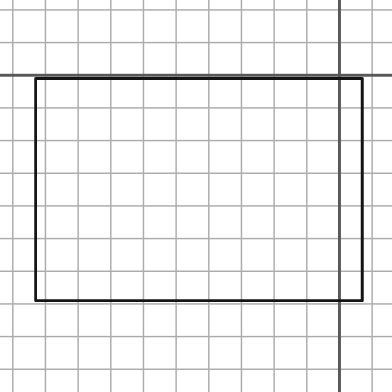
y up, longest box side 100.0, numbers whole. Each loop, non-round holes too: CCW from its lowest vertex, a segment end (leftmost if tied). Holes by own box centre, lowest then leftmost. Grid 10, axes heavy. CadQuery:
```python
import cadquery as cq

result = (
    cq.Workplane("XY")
    .moveTo(-93.0, -69.0)
    .lineTo(7.0, -69.0)
    .lineTo(7.0, -1.0)
    .lineTo(-93.0, -1.0)
    .close()
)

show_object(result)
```